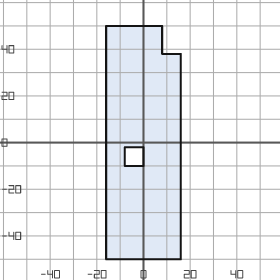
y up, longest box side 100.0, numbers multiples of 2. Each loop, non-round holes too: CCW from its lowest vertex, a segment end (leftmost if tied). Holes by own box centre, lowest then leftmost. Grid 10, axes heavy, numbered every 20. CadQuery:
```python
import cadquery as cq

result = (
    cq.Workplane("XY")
    .moveTo(-16.0, -50.0)
    .lineTo(16.0, -50.0)
    .lineTo(16.0, 38.0)
    .lineTo(8.0, 38.0)
    .lineTo(8.0, 50.0)
    .lineTo(-16.0, 50.0)
    .close()
    .moveTo(-8.0, -10.0)
    .lineTo(0.0, -10.0)
    .lineTo(0.0, -2.0)
    .lineTo(-8.0, -2.0)
    .close()
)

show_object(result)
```